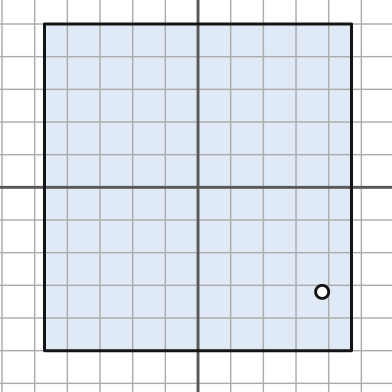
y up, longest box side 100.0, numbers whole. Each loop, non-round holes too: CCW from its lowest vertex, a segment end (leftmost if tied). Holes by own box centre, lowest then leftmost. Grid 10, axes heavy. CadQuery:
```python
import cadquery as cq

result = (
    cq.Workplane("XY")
    .moveTo(-47.0, -50.0)
    .lineTo(47.0, -50.0)
    .lineTo(47.0, 50.0)
    .lineTo(-47.0, 50.0)
    .close()
    .moveTo(38.0, -32.0)
    .circle(2.0)
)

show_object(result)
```